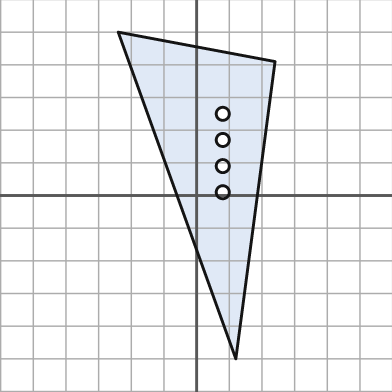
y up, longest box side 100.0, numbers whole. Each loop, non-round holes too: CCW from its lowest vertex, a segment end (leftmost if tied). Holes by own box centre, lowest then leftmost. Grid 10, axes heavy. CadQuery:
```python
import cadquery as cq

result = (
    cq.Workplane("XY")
    .moveTo(12.0, -50.0)
    .lineTo(24.0, 41.0)
    .lineTo(-24.0, 50.0)
    .close()
    .moveTo(8.0, 1.0)
    .circle(2.0)
    .moveTo(8.0, 9.0)
    .circle(2.0)
    .moveTo(8.0, 17.0)
    .circle(2.0)
    .moveTo(8.0, 25.0)
    .circle(2.0)
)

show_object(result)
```